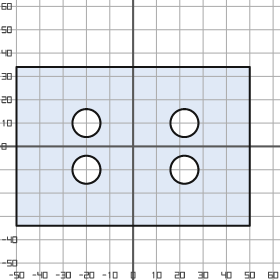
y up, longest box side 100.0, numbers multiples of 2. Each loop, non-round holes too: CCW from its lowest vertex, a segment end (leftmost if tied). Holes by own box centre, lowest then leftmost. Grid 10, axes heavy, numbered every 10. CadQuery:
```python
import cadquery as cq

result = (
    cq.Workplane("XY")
    .moveTo(-50.0, -34.0)
    .lineTo(50.0, -34.0)
    .lineTo(50.0, 34.0)
    .lineTo(-50.0, 34.0)
    .close()
    .moveTo(-20.0, -10.0)
    .circle(6.0)
    .moveTo(22.0, -10.0)
    .circle(6.0)
    .moveTo(-20.0, 10.0)
    .circle(6.0)
    .moveTo(22.0, 10.0)
    .circle(6.0)
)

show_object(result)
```